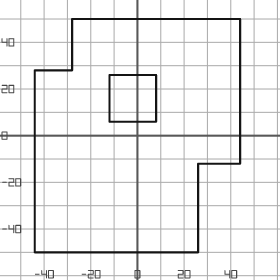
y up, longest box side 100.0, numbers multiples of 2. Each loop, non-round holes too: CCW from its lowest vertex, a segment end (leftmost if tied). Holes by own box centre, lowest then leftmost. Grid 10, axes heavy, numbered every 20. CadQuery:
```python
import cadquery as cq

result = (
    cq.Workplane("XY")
    .moveTo(-44.0, -50.0)
    .lineTo(26.0, -50.0)
    .lineTo(26.0, -12.0)
    .lineTo(44.0, -12.0)
    .lineTo(44.0, 50.0)
    .lineTo(-28.0, 50.0)
    .lineTo(-28.0, 28.0)
    .lineTo(-44.0, 28.0)
    .close()
    .moveTo(-12.0, 6.0)
    .lineTo(8.0, 6.0)
    .lineTo(8.0, 26.0)
    .lineTo(-12.0, 26.0)
    .close()
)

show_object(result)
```